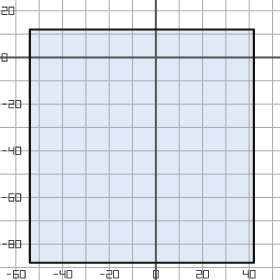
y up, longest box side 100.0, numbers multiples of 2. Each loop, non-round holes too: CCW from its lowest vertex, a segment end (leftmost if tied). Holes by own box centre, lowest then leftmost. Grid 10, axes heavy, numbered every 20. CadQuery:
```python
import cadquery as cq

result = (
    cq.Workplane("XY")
    .moveTo(-54.0, -88.0)
    .lineTo(42.0, -88.0)
    .lineTo(42.0, 12.0)
    .lineTo(-54.0, 12.0)
    .close()
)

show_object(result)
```